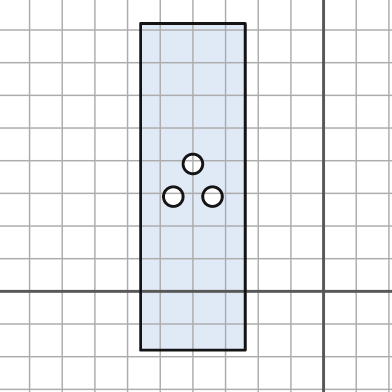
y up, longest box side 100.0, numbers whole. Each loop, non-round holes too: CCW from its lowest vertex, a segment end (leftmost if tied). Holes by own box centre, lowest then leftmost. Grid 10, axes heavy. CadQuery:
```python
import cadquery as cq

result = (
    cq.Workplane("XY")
    .moveTo(-56.0, -18.0)
    .lineTo(-24.0, -18.0)
    .lineTo(-24.0, 82.0)
    .lineTo(-56.0, 82.0)
    .close()
    .moveTo(-46.0, 29.0)
    .circle(3.0)
    .moveTo(-34.0, 29.0)
    .circle(3.0)
    .moveTo(-40.0, 39.0)
    .circle(3.0)
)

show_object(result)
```